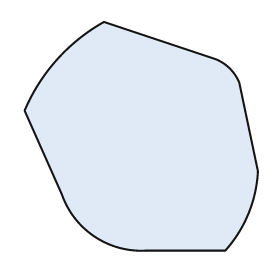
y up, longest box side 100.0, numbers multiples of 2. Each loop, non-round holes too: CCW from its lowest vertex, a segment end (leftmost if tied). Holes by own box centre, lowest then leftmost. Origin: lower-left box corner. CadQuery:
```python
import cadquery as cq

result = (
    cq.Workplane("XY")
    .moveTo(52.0, 0.0)
    .lineTo(86.0, 0.0)
    .threePointArc((96.0, 16.0), (100.0, 34.0))
    .lineTo(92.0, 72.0)
    .threePointArc((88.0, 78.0), (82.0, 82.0))
    .lineTo(34.0, 98.0)
    .threePointArc((14.0, 82.0), (0.0, 60.0))
    .lineTo(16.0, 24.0)
    .threePointArc((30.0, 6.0), (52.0, 0.0))
    .close()
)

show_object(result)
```